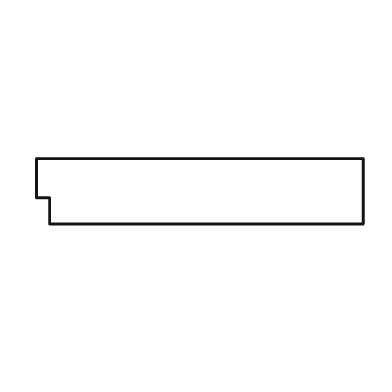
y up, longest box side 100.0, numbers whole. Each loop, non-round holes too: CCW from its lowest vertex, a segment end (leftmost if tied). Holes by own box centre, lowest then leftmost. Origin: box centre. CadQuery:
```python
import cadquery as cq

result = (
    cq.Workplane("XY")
    .moveTo(-46.0, -10.0)
    .lineTo(50.0, -10.0)
    .lineTo(50.0, 10.0)
    .lineTo(-50.0, 10.0)
    .lineTo(-50.0, -2.0)
    .lineTo(-46.0, -2.0)
    .close()
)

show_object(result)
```